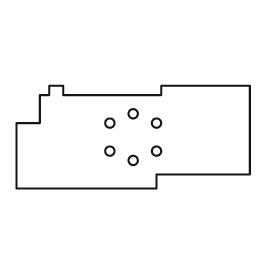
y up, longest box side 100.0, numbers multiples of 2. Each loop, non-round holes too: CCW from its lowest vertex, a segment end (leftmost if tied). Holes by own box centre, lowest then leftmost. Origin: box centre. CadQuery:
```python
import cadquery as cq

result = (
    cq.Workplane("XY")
    .moveTo(-50.0, -22.0)
    .lineTo(10.0, -22.0)
    .lineTo(10.0, -16.0)
    .lineTo(50.0, -16.0)
    .lineTo(50.0, 22.0)
    .lineTo(12.0, 22.0)
    .lineTo(12.0, 18.0)
    .lineTo(-30.0, 18.0)
    .lineTo(-30.0, 22.0)
    .lineTo(-36.0, 22.0)
    .lineTo(-36.0, 18.0)
    .lineTo(-40.0, 18.0)
    .lineTo(-40.0, 6.0)
    .lineTo(-50.0, 6.0)
    .close()
    .moveTo(0.0, -10.0)
    .circle(2.0)
    .moveTo(-10.0, -6.0)
    .circle(2.0)
    .moveTo(10.0, -6.0)
    .circle(2.0)
    .moveTo(-10.0, 6.0)
    .circle(2.0)
    .moveTo(10.0, 6.0)
    .circle(2.0)
    .moveTo(0.0, 10.0)
    .circle(2.0)
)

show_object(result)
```